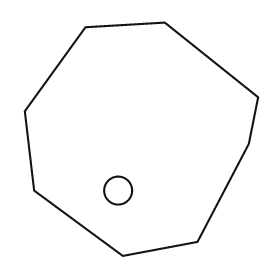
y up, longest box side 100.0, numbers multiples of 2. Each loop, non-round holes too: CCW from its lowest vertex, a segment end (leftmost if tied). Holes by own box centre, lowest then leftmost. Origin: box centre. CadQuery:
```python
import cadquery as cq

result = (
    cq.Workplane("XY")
    .moveTo(-8.0, -50.0)
    .lineTo(24.0, -44.0)
    .lineTo(46.0, -2.0)
    .lineTo(50.0, 18.0)
    .lineTo(10.0, 50.0)
    .lineTo(-24.0, 48.0)
    .lineTo(-50.0, 12.0)
    .lineTo(-46.0, -22.0)
    .close()
    .moveTo(-10.0, -22.0)
    .circle(6.0)
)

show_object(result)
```